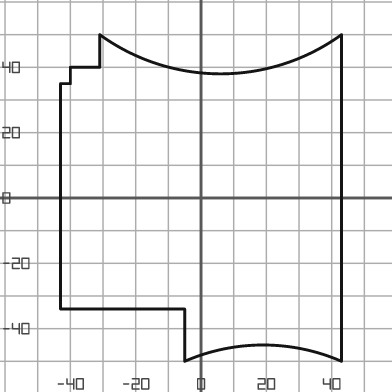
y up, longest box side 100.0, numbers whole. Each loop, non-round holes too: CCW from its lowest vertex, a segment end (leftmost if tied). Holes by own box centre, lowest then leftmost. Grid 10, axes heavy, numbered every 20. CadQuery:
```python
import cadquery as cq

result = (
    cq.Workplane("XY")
    .moveTo(-5.0, -50.0)
    .threePointArc((19.0, -45.0), (43.0, -50.0))
    .lineTo(43.0, 50.0)
    .threePointArc((6.0, 38.0), (-31.0, 50.0))
    .lineTo(-31.0, 40.0)
    .lineTo(-40.0, 40.0)
    .lineTo(-40.0, 35.0)
    .lineTo(-43.0, 35.0)
    .lineTo(-43.0, -34.0)
    .lineTo(-5.0, -34.0)
    .close()
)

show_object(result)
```